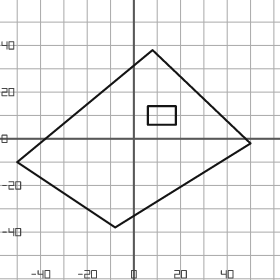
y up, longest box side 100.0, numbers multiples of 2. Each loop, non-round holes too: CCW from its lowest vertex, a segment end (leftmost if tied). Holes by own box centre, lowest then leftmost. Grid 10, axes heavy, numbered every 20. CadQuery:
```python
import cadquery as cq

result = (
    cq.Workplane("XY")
    .moveTo(-8.0, -38.0)
    .lineTo(50.0, -2.0)
    .lineTo(8.0, 38.0)
    .lineTo(-50.0, -10.0)
    .close()
    .moveTo(6.0, 6.0)
    .lineTo(18.0, 6.0)
    .lineTo(18.0, 14.0)
    .lineTo(6.0, 14.0)
    .close()
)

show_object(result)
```